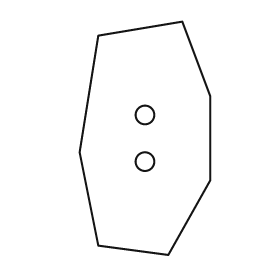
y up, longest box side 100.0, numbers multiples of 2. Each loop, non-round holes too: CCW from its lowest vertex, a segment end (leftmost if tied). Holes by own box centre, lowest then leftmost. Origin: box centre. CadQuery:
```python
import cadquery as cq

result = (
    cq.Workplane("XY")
    .moveTo(10.0, -50.0)
    .lineTo(28.0, -18.0)
    .lineTo(28.0, 18.0)
    .lineTo(16.0, 50.0)
    .lineTo(-20.0, 44.0)
    .lineTo(-28.0, -6.0)
    .lineTo(-20.0, -46.0)
    .close()
    .moveTo(0.0, -10.0)
    .circle(4.0)
    .moveTo(0.0, 10.0)
    .circle(4.0)
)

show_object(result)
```